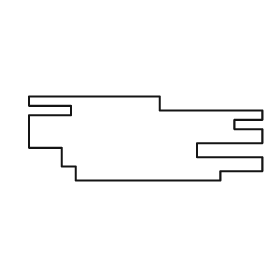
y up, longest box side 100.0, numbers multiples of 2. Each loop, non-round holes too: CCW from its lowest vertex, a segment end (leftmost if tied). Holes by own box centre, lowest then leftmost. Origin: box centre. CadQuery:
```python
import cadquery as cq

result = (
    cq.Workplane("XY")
    .moveTo(-30.0, -18.0)
    .lineTo(32.0, -18.0)
    .lineTo(32.0, -14.0)
    .lineTo(50.0, -14.0)
    .lineTo(50.0, -8.0)
    .lineTo(22.0, -8.0)
    .lineTo(22.0, -2.0)
    .lineTo(50.0, -2.0)
    .lineTo(50.0, 4.0)
    .lineTo(38.0, 4.0)
    .lineTo(38.0, 8.0)
    .lineTo(50.0, 8.0)
    .lineTo(50.0, 12.0)
    .lineTo(6.0, 12.0)
    .lineTo(6.0, 18.0)
    .lineTo(-50.0, 18.0)
    .lineTo(-50.0, 14.0)
    .lineTo(-32.0, 14.0)
    .lineTo(-32.0, 10.0)
    .lineTo(-50.0, 10.0)
    .lineTo(-50.0, -4.0)
    .lineTo(-36.0, -4.0)
    .lineTo(-36.0, -12.0)
    .lineTo(-30.0, -12.0)
    .close()
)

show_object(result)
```